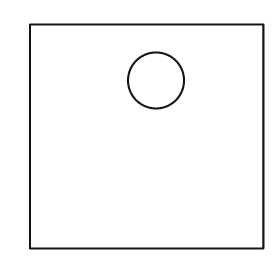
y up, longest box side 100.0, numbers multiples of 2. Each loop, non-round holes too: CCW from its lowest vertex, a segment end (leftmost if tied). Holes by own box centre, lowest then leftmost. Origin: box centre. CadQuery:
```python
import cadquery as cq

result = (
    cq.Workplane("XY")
    .moveTo(-50.0, -48.0)
    .lineTo(50.0, -48.0)
    .lineTo(50.0, 48.0)
    .lineTo(-50.0, 48.0)
    .close()
    .moveTo(4.0, 24.0)
    .circle(12.0)
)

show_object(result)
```